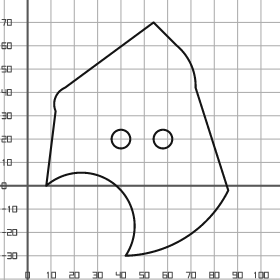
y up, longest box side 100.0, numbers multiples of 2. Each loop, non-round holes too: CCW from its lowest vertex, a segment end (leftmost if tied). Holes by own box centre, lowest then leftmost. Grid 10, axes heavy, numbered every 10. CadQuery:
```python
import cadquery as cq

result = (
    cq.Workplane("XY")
    .moveTo(42.0, -30.0)
    .threePointArc((68.0, -22.0), (86.0, -2.0))
    .lineTo(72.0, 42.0)
    .threePointArc((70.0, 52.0), (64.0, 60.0))
    .lineTo(54.0, 70.0)
    .lineTo(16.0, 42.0)
    .threePointArc((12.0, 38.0), (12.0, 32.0))
    .lineTo(8.0, 0.0)
    .threePointArc((38.0, 0.0), (42.0, -30.0))
    .close()
    .moveTo(40.0, 20.0)
    .circle(4.0)
    .moveTo(58.0, 20.0)
    .circle(4.0)
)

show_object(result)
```